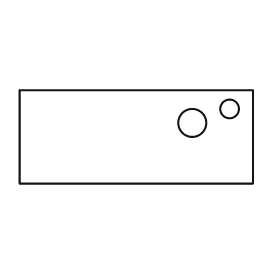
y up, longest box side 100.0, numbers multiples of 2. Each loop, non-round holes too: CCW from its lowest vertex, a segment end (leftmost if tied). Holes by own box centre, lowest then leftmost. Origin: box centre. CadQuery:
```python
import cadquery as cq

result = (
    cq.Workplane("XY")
    .moveTo(-50.0, -20.0)
    .lineTo(50.0, -20.0)
    .lineTo(50.0, 20.0)
    .lineTo(-50.0, 20.0)
    .close()
    .moveTo(24.0, 6.0)
    .circle(6.0)
    .moveTo(40.0, 12.0)
    .circle(4.0)
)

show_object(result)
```